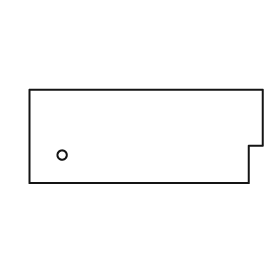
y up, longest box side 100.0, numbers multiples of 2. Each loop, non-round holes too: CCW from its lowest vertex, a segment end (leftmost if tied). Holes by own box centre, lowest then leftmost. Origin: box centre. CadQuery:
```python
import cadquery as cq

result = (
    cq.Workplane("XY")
    .moveTo(-50.0, -20.0)
    .lineTo(44.0, -20.0)
    .lineTo(44.0, -4.0)
    .lineTo(50.0, -4.0)
    .lineTo(50.0, 20.0)
    .lineTo(-50.0, 20.0)
    .close()
    .moveTo(-36.0, -8.0)
    .circle(2.0)
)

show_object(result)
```